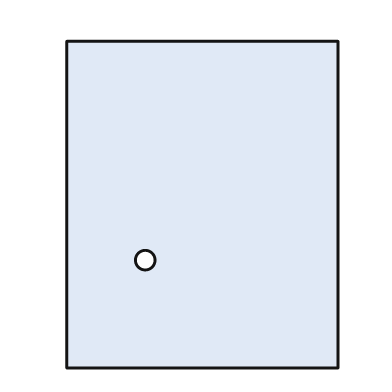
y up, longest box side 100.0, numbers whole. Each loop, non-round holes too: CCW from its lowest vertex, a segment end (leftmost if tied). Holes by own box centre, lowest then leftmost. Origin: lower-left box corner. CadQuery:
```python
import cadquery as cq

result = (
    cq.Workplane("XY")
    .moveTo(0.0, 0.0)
    .lineTo(83.0, 0.0)
    .lineTo(83.0, 100.0)
    .lineTo(0.0, 100.0)
    .close()
    .moveTo(24.0, 33.0)
    .circle(3.0)
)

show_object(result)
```